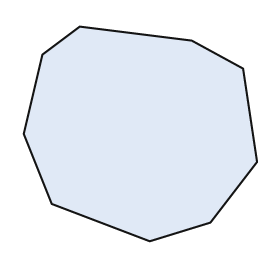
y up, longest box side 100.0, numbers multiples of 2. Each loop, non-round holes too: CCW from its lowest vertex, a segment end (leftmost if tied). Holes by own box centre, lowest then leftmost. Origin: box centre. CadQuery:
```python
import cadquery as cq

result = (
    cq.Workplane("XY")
    .moveTo(4.0, -46.0)
    .lineTo(30.0, -38.0)
    .lineTo(50.0, -12.0)
    .lineTo(44.0, 28.0)
    .lineTo(22.0, 40.0)
    .lineTo(-26.0, 46.0)
    .lineTo(-42.0, 34.0)
    .lineTo(-50.0, 0.0)
    .lineTo(-38.0, -30.0)
    .close()
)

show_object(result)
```